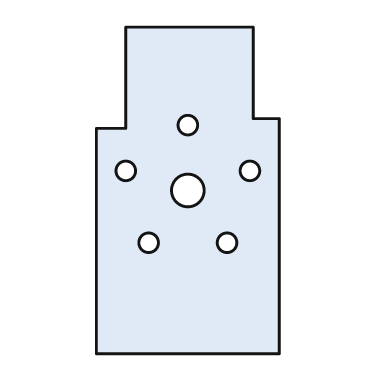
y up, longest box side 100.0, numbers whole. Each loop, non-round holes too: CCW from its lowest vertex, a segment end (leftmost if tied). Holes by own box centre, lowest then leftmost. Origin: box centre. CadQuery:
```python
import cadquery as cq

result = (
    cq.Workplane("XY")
    .moveTo(-28.0, -50.0)
    .lineTo(28.0, -50.0)
    .lineTo(28.0, 22.0)
    .lineTo(20.0, 22.0)
    .lineTo(20.0, 50.0)
    .lineTo(-19.0, 50.0)
    .lineTo(-19.0, 19.0)
    .lineTo(-28.0, 19.0)
    .close()
    .moveTo(-12.0, -16.0)
    .circle(3.0)
    .moveTo(12.0, -16.0)
    .circle(3.0)
    .moveTo(0.0, 0.0)
    .circle(5.0)
    .moveTo(-19.0, 6.0)
    .circle(3.0)
    .moveTo(19.0, 6.0)
    .circle(3.0)
    .moveTo(0.0, 20.0)
    .circle(3.0)
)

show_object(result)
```